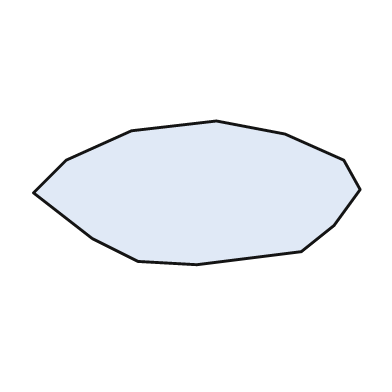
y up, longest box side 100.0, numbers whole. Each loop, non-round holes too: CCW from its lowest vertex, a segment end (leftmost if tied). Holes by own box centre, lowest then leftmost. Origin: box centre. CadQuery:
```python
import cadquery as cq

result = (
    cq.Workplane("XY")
    .moveTo(0.0, -22.0)
    .lineTo(32.0, -18.0)
    .lineTo(42.0, -10.0)
    .lineTo(50.0, 1.0)
    .lineTo(45.0, 10.0)
    .lineTo(27.0, 18.0)
    .lineTo(6.0, 22.0)
    .lineTo(-20.0, 19.0)
    .lineTo(-40.0, 10.0)
    .lineTo(-50.0, 0.0)
    .lineTo(-32.0, -14.0)
    .lineTo(-18.0, -21.0)
    .close()
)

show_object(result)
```